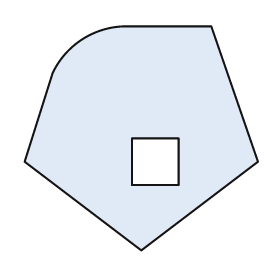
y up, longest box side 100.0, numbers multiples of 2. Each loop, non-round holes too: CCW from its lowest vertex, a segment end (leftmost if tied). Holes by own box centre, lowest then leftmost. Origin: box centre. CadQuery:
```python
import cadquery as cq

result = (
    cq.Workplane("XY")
    .moveTo(0.0, -48.0)
    .lineTo(50.0, -10.0)
    .lineTo(30.0, 48.0)
    .lineTo(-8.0, 48.0)
    .threePointArc((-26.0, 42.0), (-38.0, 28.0))
    .lineTo(-50.0, -10.0)
    .close()
    .moveTo(-4.0, -20.0)
    .lineTo(16.0, -20.0)
    .lineTo(16.0, 0.0)
    .lineTo(-4.0, 0.0)
    .close()
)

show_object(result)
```